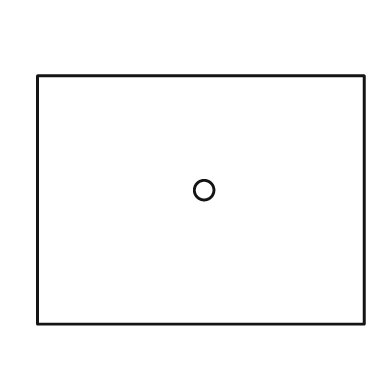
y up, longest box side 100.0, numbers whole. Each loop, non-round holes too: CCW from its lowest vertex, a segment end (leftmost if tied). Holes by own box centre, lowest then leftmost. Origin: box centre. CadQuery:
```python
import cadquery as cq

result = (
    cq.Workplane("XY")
    .moveTo(-50.0, -38.0)
    .lineTo(50.0, -38.0)
    .lineTo(50.0, 38.0)
    .lineTo(-50.0, 38.0)
    .close()
    .moveTo(1.0, 3.0)
    .circle(3.0)
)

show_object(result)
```